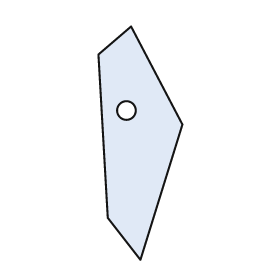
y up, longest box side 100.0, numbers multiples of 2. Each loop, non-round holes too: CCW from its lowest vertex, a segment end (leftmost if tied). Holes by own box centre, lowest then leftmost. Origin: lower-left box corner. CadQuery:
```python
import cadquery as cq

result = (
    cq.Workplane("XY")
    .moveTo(18.0, 0.0)
    .lineTo(36.0, 58.0)
    .lineTo(14.0, 100.0)
    .lineTo(0.0, 88.0)
    .lineTo(4.0, 18.0)
    .close()
    .moveTo(12.0, 64.0)
    .circle(4.0)
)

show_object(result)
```